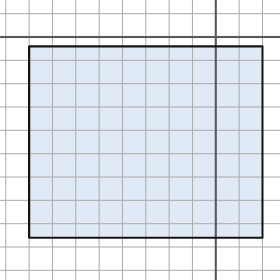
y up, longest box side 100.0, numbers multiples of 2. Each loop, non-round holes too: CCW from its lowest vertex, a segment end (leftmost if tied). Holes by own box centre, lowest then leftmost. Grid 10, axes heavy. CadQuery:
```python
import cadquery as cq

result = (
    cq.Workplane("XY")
    .moveTo(-80.0, -86.0)
    .lineTo(20.0, -86.0)
    .lineTo(20.0, -4.0)
    .lineTo(-80.0, -4.0)
    .close()
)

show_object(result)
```